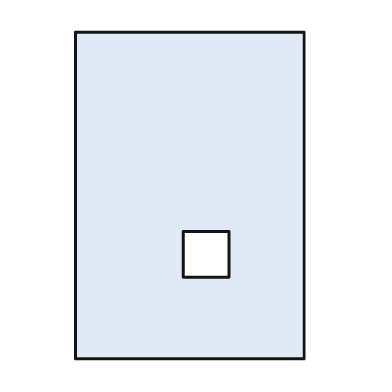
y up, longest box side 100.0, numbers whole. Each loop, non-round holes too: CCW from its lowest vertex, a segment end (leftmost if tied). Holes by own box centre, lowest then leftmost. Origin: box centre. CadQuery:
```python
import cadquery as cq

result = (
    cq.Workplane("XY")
    .moveTo(-35.0, -50.0)
    .lineTo(35.0, -50.0)
    .lineTo(35.0, 50.0)
    .lineTo(-35.0, 50.0)
    .close()
    .moveTo(-2.0, -25.0)
    .lineTo(12.0, -25.0)
    .lineTo(12.0, -11.0)
    .lineTo(-2.0, -11.0)
    .close()
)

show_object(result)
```